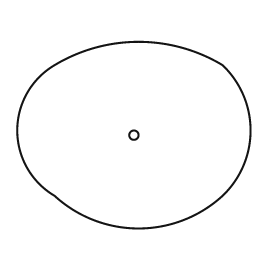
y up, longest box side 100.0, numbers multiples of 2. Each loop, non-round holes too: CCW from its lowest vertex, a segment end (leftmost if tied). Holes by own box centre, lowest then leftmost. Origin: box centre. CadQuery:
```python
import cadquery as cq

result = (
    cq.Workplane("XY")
    .moveTo(-34.0, -26.0)
    .threePointArc((2.0, -40.0), (38.0, -26.0))
    .threePointArc((50.0, 2.0), (38.0, 30.0))
    .threePointArc((2.0, 40.0), (-34.0, 30.0))
    .threePointArc((-50.0, 2.0), (-34.0, -26.0))
    .close()
    .moveTo(0.0, 0.0)
    .circle(2.0)
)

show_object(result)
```